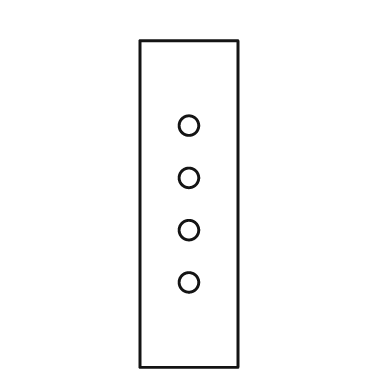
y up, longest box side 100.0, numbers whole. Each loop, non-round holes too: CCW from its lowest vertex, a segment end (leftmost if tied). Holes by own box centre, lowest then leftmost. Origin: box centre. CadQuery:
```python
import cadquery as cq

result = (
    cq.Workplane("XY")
    .moveTo(-15.0, -50.0)
    .lineTo(15.0, -50.0)
    .lineTo(15.0, 50.0)
    .lineTo(-15.0, 50.0)
    .close()
    .moveTo(0.0, -24.0)
    .circle(3.0)
    .moveTo(0.0, -8.0)
    .circle(3.0)
    .moveTo(0.0, 8.0)
    .circle(3.0)
    .moveTo(0.0, 24.0)
    .circle(3.0)
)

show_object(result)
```